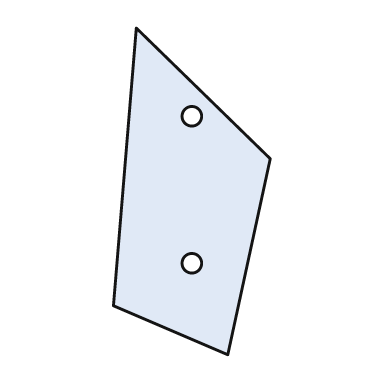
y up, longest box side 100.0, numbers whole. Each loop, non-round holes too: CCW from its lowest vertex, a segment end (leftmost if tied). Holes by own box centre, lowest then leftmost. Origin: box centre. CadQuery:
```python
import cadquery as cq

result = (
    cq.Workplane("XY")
    .moveTo(11.0, -50.0)
    .lineTo(24.0, 10.0)
    .lineTo(-17.0, 50.0)
    .lineTo(-24.0, -35.0)
    .close()
    .moveTo(0.0, -22.0)
    .circle(3.0)
    .moveTo(0.0, 23.0)
    .circle(3.0)
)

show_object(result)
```